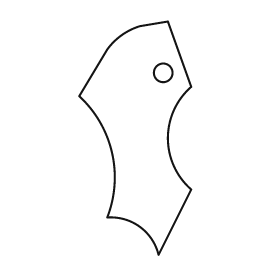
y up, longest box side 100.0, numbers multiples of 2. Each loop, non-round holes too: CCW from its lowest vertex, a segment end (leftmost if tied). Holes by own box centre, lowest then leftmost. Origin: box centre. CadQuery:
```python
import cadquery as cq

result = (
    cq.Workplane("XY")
    .moveTo(10.0, -50.0)
    .lineTo(24.0, -22.0)
    .threePointArc((14.0, 0.0), (24.0, 22.0))
    .lineTo(14.0, 50.0)
    .lineTo(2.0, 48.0)
    .threePointArc((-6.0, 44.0), (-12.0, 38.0))
    .lineTo(-24.0, 18.0)
    .threePointArc((-10.0, -6.0), (-12.0, -34.0))
    .threePointArc((2.0, -38.0), (10.0, -50.0))
    .close()
    .moveTo(12.0, 28.0)
    .circle(4.0)
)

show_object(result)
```